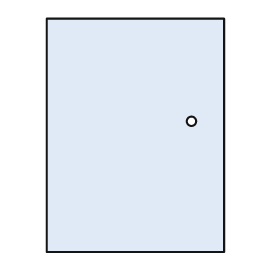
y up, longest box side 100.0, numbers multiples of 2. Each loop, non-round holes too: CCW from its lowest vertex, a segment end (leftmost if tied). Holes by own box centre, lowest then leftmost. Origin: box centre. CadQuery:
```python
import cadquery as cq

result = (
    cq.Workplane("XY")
    .moveTo(-38.0, -50.0)
    .lineTo(38.0, -50.0)
    .lineTo(38.0, 50.0)
    .lineTo(-38.0, 50.0)
    .close()
    .moveTo(24.0, 6.0)
    .circle(2.0)
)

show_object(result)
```